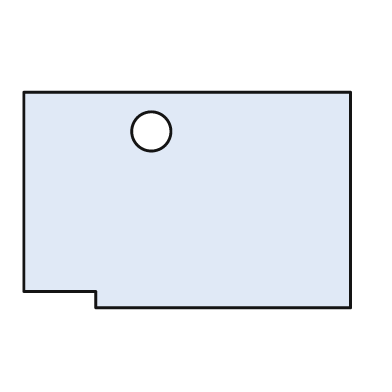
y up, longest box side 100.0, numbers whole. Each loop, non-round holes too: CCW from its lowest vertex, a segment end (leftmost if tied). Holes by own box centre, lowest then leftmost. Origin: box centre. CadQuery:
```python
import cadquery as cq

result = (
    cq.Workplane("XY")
    .moveTo(-28.0, -33.0)
    .lineTo(50.0, -33.0)
    .lineTo(50.0, 33.0)
    .lineTo(-50.0, 33.0)
    .lineTo(-50.0, -28.0)
    .lineTo(-28.0, -28.0)
    .close()
    .moveTo(-11.0, 21.0)
    .circle(6.0)
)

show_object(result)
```